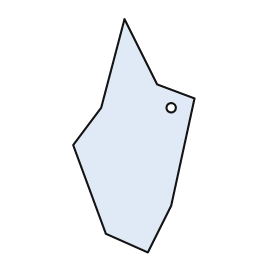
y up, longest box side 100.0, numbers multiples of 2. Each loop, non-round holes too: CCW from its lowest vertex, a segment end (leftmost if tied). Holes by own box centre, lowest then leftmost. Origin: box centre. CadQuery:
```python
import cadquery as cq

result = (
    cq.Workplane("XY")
    .moveTo(6.0, -50.0)
    .lineTo(16.0, -30.0)
    .lineTo(26.0, 16.0)
    .lineTo(10.0, 22.0)
    .lineTo(-4.0, 50.0)
    .lineTo(-14.0, 12.0)
    .lineTo(-26.0, -4.0)
    .lineTo(-12.0, -42.0)
    .close()
    .moveTo(16.0, 12.0)
    .circle(2.0)
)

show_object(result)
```